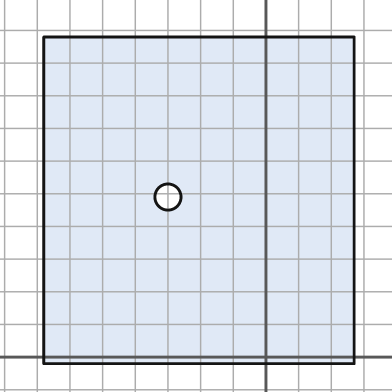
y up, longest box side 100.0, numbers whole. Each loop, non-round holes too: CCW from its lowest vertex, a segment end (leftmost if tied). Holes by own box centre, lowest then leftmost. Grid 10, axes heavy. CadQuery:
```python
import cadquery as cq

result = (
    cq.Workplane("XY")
    .moveTo(-68.0, -2.0)
    .lineTo(27.0, -2.0)
    .lineTo(27.0, 98.0)
    .lineTo(-68.0, 98.0)
    .close()
    .moveTo(-30.0, 49.0)
    .circle(4.0)
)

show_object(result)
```